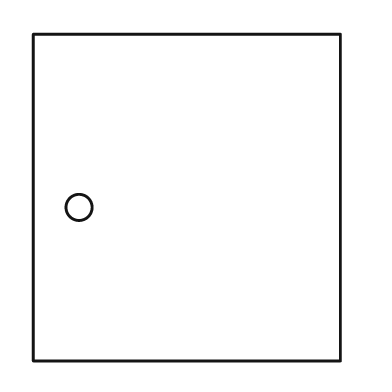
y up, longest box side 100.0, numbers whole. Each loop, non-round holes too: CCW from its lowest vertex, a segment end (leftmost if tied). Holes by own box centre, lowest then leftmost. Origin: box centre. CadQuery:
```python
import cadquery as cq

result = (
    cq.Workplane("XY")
    .moveTo(-47.0, -50.0)
    .lineTo(47.0, -50.0)
    .lineTo(47.0, 50.0)
    .lineTo(-47.0, 50.0)
    .close()
    .moveTo(-33.0, -3.0)
    .circle(4.0)
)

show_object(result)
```